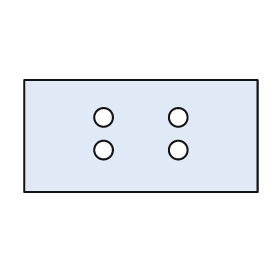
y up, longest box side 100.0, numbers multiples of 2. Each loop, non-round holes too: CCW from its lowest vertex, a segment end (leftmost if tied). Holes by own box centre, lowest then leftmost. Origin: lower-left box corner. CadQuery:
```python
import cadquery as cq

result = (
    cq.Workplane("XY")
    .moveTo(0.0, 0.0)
    .lineTo(100.0, 0.0)
    .lineTo(100.0, 48.0)
    .lineTo(0.0, 48.0)
    .close()
    .moveTo(34.0, 18.0)
    .circle(4.0)
    .moveTo(66.0, 18.0)
    .circle(4.0)
    .moveTo(34.0, 32.0)
    .circle(4.0)
    .moveTo(66.0, 32.0)
    .circle(4.0)
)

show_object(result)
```